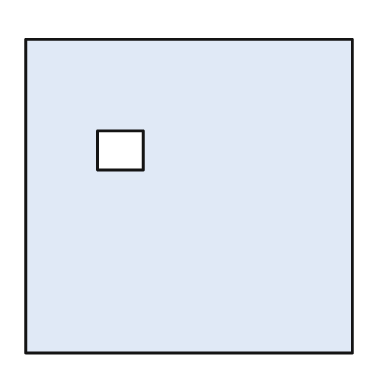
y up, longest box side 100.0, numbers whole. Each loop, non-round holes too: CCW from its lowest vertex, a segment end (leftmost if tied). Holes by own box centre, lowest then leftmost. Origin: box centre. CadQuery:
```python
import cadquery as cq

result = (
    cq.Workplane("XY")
    .moveTo(-50.0, -48.0)
    .lineTo(50.0, -48.0)
    .lineTo(50.0, 48.0)
    .lineTo(-50.0, 48.0)
    .close()
    .moveTo(-28.0, 8.0)
    .lineTo(-14.0, 8.0)
    .lineTo(-14.0, 20.0)
    .lineTo(-28.0, 20.0)
    .close()
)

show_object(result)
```